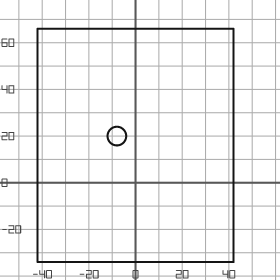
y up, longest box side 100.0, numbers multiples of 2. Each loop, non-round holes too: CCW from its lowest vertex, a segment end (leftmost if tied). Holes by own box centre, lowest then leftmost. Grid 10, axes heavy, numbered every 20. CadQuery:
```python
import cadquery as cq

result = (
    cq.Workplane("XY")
    .moveTo(-42.0, -34.0)
    .lineTo(42.0, -34.0)
    .lineTo(42.0, 66.0)
    .lineTo(-42.0, 66.0)
    .close()
    .moveTo(-8.0, 20.0)
    .circle(4.0)
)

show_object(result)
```